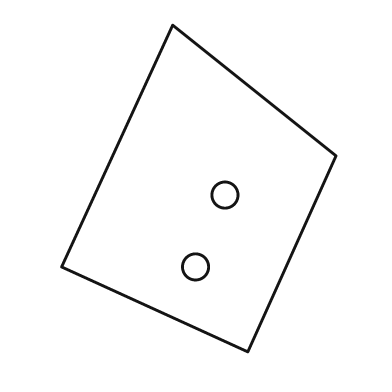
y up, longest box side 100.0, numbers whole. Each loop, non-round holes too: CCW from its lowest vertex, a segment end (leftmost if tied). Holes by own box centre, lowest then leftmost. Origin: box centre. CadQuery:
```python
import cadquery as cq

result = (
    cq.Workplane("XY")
    .moveTo(15.0, -50.0)
    .lineTo(42.0, 10.0)
    .lineTo(-8.0, 50.0)
    .lineTo(-42.0, -24.0)
    .close()
    .moveTo(-1.0, -24.0)
    .circle(4.0)
    .moveTo(8.0, -2.0)
    .circle(4.0)
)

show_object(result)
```